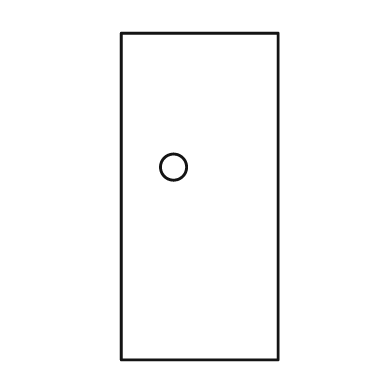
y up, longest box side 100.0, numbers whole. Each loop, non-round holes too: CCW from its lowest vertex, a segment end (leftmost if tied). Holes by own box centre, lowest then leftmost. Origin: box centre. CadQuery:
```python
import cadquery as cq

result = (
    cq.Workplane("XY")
    .moveTo(-24.0, -50.0)
    .lineTo(24.0, -50.0)
    .lineTo(24.0, 50.0)
    .lineTo(-24.0, 50.0)
    .close()
    .moveTo(-8.0, 9.0)
    .circle(4.0)
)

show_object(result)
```